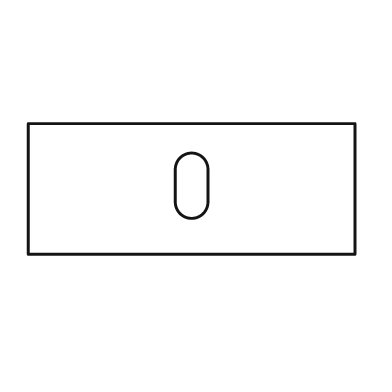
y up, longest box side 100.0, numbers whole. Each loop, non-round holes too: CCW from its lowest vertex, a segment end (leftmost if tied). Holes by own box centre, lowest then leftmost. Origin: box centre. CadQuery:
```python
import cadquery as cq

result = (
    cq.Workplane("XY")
    .moveTo(-50.0, -20.0)
    .lineTo(50.0, -20.0)
    .lineTo(50.0, 20.0)
    .lineTo(-50.0, 20.0)
    .close()
    .moveTo(-5.0, -4.0)
    .threePointArc((0.0, -9.0), (5.0, -4.0))
    .lineTo(5.0, 6.0)
    .threePointArc((0.0, 11.0), (-5.0, 6.0))
    .close()
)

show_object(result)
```